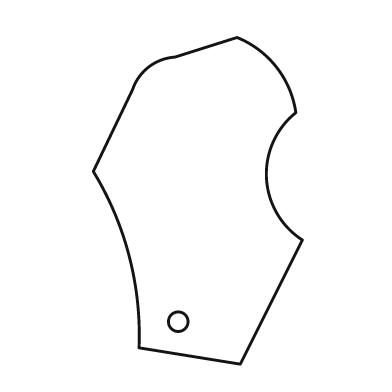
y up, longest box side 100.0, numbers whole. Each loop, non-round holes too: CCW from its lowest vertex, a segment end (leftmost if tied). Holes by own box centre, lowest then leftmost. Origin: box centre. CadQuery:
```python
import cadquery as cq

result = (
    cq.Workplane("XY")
    .moveTo(13.0, -50.0)
    .lineTo(32.0, -12.0)
    .threePointArc((21.0, 7.0), (30.0, 27.0))
    .threePointArc((24.0, 41.0), (12.0, 50.0))
    .lineTo(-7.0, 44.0)
    .threePointArc((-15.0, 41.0), (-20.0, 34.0))
    .lineTo(-32.0, 9.0)
    .threePointArc((-21.0, -17.0), (-18.0, -45.0))
    .close()
    .moveTo(-6.0, -37.0)
    .circle(3.0)
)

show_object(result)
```